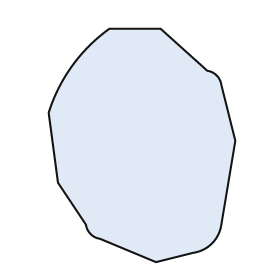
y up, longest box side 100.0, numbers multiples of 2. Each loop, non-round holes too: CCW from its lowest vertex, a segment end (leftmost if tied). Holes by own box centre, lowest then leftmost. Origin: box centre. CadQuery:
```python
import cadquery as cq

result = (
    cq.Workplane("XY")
    .moveTo(6.0, -50.0)
    .lineTo(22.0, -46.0)
    .threePointArc((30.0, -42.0), (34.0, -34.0))
    .lineTo(40.0, 2.0)
    .lineTo(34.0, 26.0)
    .threePointArc((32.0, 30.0), (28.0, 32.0))
    .lineTo(8.0, 50.0)
    .lineTo(-14.0, 50.0)
    .threePointArc((-30.0, 34.0), (-40.0, 14.0))
    .lineTo(-36.0, -16.0)
    .lineTo(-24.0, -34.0)
    .threePointArc((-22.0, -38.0), (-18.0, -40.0))
    .close()
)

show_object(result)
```